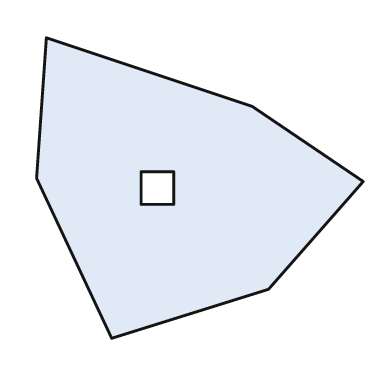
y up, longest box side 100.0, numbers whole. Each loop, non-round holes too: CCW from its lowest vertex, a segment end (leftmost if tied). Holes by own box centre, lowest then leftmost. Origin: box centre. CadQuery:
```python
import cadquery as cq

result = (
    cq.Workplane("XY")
    .moveTo(-27.0, -46.0)
    .lineTo(21.0, -31.0)
    .lineTo(50.0, 2.0)
    .lineTo(16.0, 25.0)
    .lineTo(-47.0, 46.0)
    .lineTo(-50.0, 3.0)
    .close()
    .moveTo(-18.0, -5.0)
    .lineTo(-8.0, -5.0)
    .lineTo(-8.0, 5.0)
    .lineTo(-18.0, 5.0)
    .close()
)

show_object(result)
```